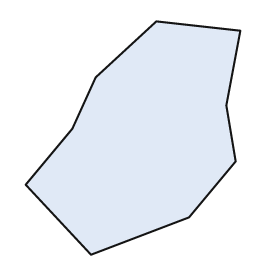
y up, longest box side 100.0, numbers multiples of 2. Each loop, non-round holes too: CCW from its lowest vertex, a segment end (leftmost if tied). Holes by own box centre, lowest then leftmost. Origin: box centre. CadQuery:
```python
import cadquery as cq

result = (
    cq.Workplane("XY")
    .moveTo(-18.0, -50.0)
    .lineTo(24.0, -34.0)
    .lineTo(44.0, -10.0)
    .lineTo(40.0, 14.0)
    .lineTo(46.0, 46.0)
    .lineTo(10.0, 50.0)
    .lineTo(-16.0, 26.0)
    .lineTo(-26.0, 4.0)
    .lineTo(-46.0, -20.0)
    .close()
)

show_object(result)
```